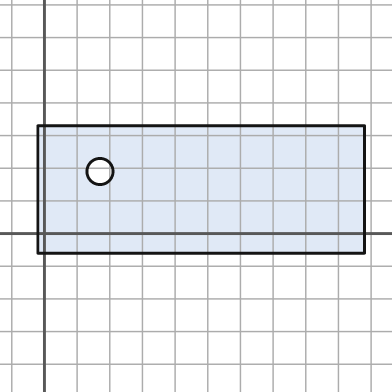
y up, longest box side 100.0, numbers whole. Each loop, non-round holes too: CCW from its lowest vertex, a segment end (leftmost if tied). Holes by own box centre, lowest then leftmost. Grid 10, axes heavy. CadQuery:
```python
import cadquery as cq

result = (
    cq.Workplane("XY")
    .moveTo(-2.0, -6.0)
    .lineTo(98.0, -6.0)
    .lineTo(98.0, 33.0)
    .lineTo(-2.0, 33.0)
    .close()
    .moveTo(17.0, 19.0)
    .circle(4.0)
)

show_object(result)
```